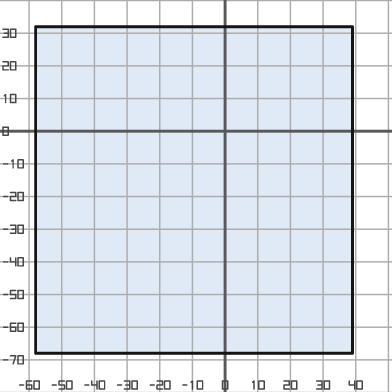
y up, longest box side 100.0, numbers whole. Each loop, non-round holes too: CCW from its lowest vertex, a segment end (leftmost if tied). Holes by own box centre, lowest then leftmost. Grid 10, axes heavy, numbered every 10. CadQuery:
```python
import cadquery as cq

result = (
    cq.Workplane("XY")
    .moveTo(-58.0, -68.0)
    .lineTo(39.0, -68.0)
    .lineTo(39.0, 32.0)
    .lineTo(-58.0, 32.0)
    .close()
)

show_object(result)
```